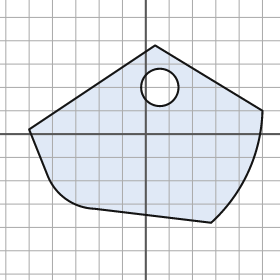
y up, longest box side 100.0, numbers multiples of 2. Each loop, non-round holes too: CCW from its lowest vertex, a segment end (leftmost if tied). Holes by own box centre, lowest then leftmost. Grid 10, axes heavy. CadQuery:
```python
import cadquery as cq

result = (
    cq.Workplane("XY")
    .moveTo(28.0, -38.0)
    .threePointArc((44.0, -16.0), (50.0, 10.0))
    .lineTo(4.0, 38.0)
    .lineTo(-50.0, 2.0)
    .lineTo(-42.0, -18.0)
    .threePointArc((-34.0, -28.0), (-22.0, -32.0))
    .close()
    .moveTo(6.0, 20.0)
    .circle(8.0)
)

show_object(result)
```